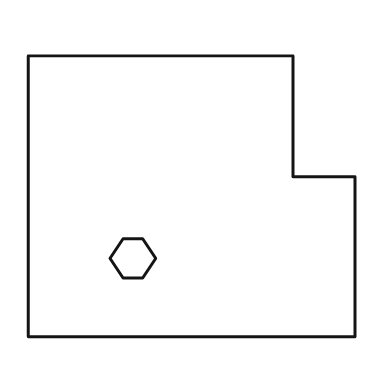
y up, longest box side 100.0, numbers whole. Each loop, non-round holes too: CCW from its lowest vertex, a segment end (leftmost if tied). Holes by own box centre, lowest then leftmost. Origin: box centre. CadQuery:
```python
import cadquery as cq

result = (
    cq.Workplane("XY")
    .moveTo(-50.0, -43.0)
    .lineTo(50.0, -43.0)
    .lineTo(50.0, 6.0)
    .lineTo(31.0, 6.0)
    .lineTo(31.0, 43.0)
    .lineTo(-50.0, 43.0)
    .close()
    .moveTo(-21.0, -25.0)
    .lineTo(-15.0, -25.0)
    .lineTo(-11.0, -19.0)
    .lineTo(-15.0, -13.0)
    .lineTo(-21.0, -13.0)
    .lineTo(-25.0, -19.0)
    .close()
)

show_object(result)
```